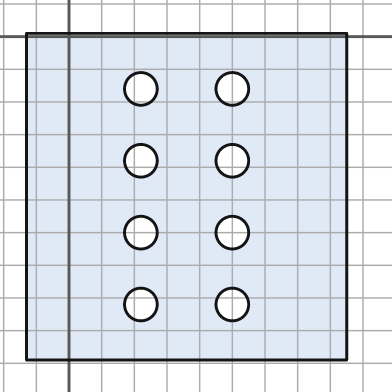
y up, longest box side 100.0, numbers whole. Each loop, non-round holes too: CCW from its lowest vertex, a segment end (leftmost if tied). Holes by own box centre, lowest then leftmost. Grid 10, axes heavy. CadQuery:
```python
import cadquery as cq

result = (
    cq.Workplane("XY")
    .moveTo(-13.0, -99.0)
    .lineTo(85.0, -99.0)
    .lineTo(85.0, 1.0)
    .lineTo(-13.0, 1.0)
    .close()
    .moveTo(22.0, -82.0)
    .circle(5.0)
    .moveTo(50.0, -82.0)
    .circle(5.0)
    .moveTo(22.0, -60.0)
    .circle(5.0)
    .moveTo(50.0, -60.0)
    .circle(5.0)
    .moveTo(22.0, -38.0)
    .circle(5.0)
    .moveTo(50.0, -38.0)
    .circle(5.0)
    .moveTo(22.0, -16.0)
    .circle(5.0)
    .moveTo(50.0, -16.0)
    .circle(5.0)
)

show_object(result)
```